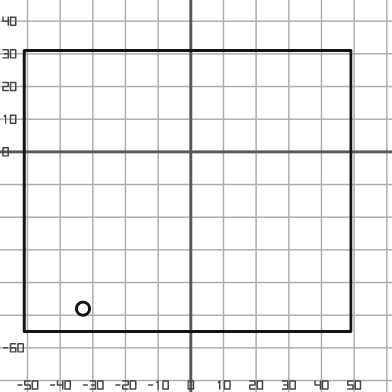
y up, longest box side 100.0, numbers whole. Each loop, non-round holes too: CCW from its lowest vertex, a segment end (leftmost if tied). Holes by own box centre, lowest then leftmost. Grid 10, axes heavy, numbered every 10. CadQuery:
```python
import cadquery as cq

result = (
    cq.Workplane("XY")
    .moveTo(-51.0, -55.0)
    .lineTo(49.0, -55.0)
    .lineTo(49.0, 31.0)
    .lineTo(-51.0, 31.0)
    .close()
    .moveTo(-33.0, -48.0)
    .circle(2.0)
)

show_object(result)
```